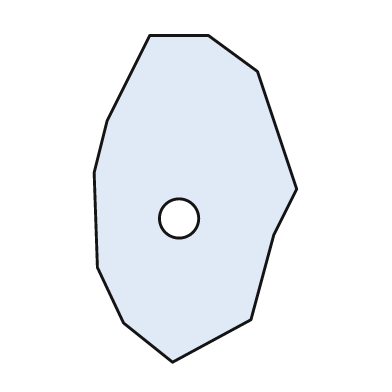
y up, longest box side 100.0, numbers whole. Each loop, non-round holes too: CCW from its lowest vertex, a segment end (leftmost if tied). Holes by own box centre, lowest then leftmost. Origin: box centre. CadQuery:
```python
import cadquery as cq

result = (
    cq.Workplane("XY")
    .moveTo(-7.0, -50.0)
    .lineTo(17.0, -37.0)
    .lineTo(24.0, -11.0)
    .lineTo(31.0, 3.0)
    .lineTo(19.0, 39.0)
    .lineTo(4.0, 50.0)
    .lineTo(-14.0, 50.0)
    .lineTo(-27.0, 24.0)
    .lineTo(-31.0, 8.0)
    .lineTo(-30.0, -21.0)
    .lineTo(-22.0, -38.0)
    .close()
    .moveTo(-5.0, -6.0)
    .circle(6.0)
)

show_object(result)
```